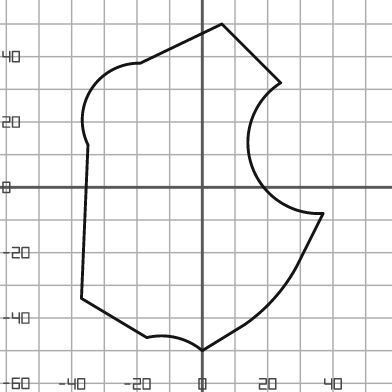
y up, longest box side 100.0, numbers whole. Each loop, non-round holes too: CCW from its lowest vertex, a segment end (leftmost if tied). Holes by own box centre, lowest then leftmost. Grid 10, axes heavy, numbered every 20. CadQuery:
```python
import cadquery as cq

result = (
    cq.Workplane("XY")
    .moveTo(0.0, -50.0)
    .lineTo(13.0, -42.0)
    .threePointArc((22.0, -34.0), (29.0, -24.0))
    .lineTo(37.0, -8.0)
    .threePointArc((15.0, 7.0), (24.0, 32.0))
    .lineTo(6.0, 50.0)
    .lineTo(-19.0, 38.0)
    .threePointArc((-34.0, 30.0), (-35.0, 13.0))
    .lineTo(-37.0, -34.0)
    .lineTo(-17.0, -46.0)
    .threePointArc((-8.0, -46.0), (0.0, -50.0))
    .close()
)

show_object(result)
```